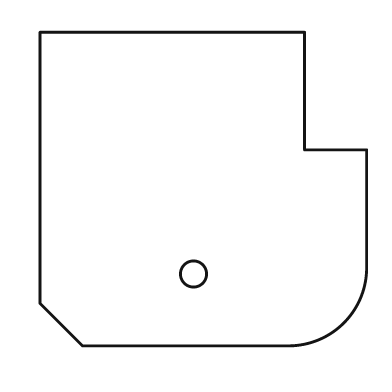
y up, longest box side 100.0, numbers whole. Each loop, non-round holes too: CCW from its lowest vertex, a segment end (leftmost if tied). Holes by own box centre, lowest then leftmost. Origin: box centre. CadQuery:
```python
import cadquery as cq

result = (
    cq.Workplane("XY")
    .moveTo(-37.0, -48.0)
    .lineTo(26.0, -48.0)
    .threePointArc((43.0, -41.0), (50.0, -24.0))
    .lineTo(50.0, 12.0)
    .lineTo(31.0, 12.0)
    .lineTo(31.0, 48.0)
    .lineTo(-50.0, 48.0)
    .lineTo(-50.0, -35.0)
    .close()
    .moveTo(-3.0, -26.0)
    .circle(4.0)
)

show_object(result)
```